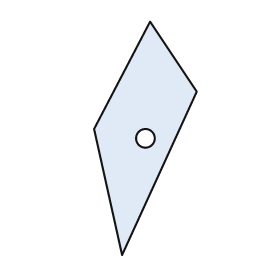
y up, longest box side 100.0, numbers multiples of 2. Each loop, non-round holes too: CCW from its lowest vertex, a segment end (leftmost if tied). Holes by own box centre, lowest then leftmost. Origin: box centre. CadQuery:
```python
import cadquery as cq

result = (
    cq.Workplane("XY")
    .moveTo(-10.0, -50.0)
    .lineTo(22.0, 20.0)
    .lineTo(2.0, 50.0)
    .lineTo(-22.0, 4.0)
    .close()
    .moveTo(0.0, 0.0)
    .circle(4.0)
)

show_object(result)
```